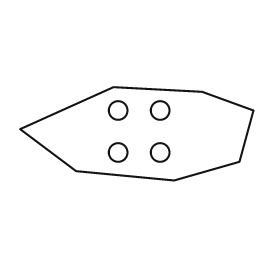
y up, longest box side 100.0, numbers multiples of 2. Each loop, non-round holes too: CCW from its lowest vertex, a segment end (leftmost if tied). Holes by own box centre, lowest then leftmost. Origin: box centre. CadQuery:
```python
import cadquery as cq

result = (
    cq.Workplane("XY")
    .moveTo(16.0, -20.0)
    .lineTo(44.0, -12.0)
    .lineTo(50.0, 10.0)
    .lineTo(28.0, 18.0)
    .lineTo(-10.0, 20.0)
    .lineTo(-50.0, 2.0)
    .lineTo(-26.0, -16.0)
    .close()
    .moveTo(-8.0, -8.0)
    .circle(4.0)
    .moveTo(10.0, -8.0)
    .circle(4.0)
    .moveTo(-8.0, 10.0)
    .circle(4.0)
    .moveTo(10.0, 10.0)
    .circle(4.0)
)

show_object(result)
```